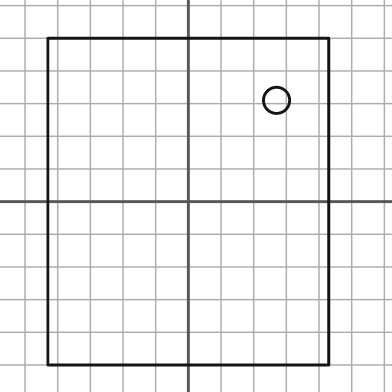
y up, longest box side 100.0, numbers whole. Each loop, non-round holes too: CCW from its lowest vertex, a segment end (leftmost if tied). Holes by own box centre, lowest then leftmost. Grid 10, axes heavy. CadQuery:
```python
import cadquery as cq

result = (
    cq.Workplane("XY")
    .moveTo(-43.0, -50.0)
    .lineTo(43.0, -50.0)
    .lineTo(43.0, 50.0)
    .lineTo(-43.0, 50.0)
    .close()
    .moveTo(27.0, 31.0)
    .circle(4.0)
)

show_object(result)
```